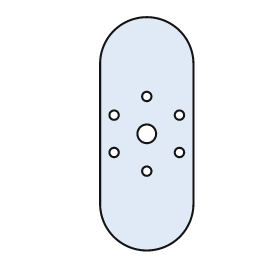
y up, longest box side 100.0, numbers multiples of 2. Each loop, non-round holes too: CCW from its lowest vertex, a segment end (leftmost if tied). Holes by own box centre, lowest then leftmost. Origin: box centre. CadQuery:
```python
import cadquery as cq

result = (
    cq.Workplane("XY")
    .moveTo(-20.0, -30.0)
    .threePointArc((0.0, -50.0), (20.0, -30.0))
    .lineTo(20.0, 30.0)
    .threePointArc((0.0, 50.0), (-20.0, 30.0))
    .close()
    .moveTo(0.0, -16.0)
    .circle(2.0)
    .moveTo(-14.0, -8.0)
    .circle(2.0)
    .moveTo(14.0, -8.0)
    .circle(2.0)
    .moveTo(0.0, 0.0)
    .circle(4.0)
    .moveTo(-14.0, 8.0)
    .circle(2.0)
    .moveTo(14.0, 8.0)
    .circle(2.0)
    .moveTo(0.0, 16.0)
    .circle(2.0)
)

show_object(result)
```